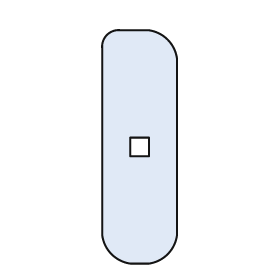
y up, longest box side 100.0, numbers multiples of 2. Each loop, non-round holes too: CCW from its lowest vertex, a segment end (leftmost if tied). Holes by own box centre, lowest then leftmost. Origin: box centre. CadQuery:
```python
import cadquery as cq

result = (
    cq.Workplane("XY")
    .moveTo(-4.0, -50.0)
    .lineTo(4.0, -50.0)
    .threePointArc((12.0, -46.0), (16.0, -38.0))
    .lineTo(16.0, 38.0)
    .threePointArc((12.0, 46.0), (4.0, 50.0))
    .lineTo(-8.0, 50.0)
    .threePointArc((-14.0, 48.0), (-16.0, 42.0))
    .lineTo(-16.0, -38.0)
    .threePointArc((-12.0, -46.0), (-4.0, -50.0))
    .close()
    .moveTo(-4.0, -4.0)
    .lineTo(4.0, -4.0)
    .lineTo(4.0, 4.0)
    .lineTo(-4.0, 4.0)
    .close()
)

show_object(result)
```